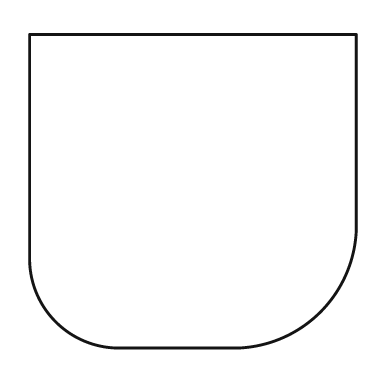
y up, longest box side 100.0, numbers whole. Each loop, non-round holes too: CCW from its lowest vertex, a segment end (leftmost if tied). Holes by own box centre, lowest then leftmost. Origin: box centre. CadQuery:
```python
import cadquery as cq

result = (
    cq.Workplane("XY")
    .moveTo(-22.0, -48.0)
    .lineTo(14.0, -48.0)
    .threePointArc((39.0, -37.0), (50.0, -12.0))
    .lineTo(50.0, 48.0)
    .lineTo(-50.0, 48.0)
    .lineTo(-50.0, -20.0)
    .threePointArc((-42.0, -40.0), (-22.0, -48.0))
    .close()
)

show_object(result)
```